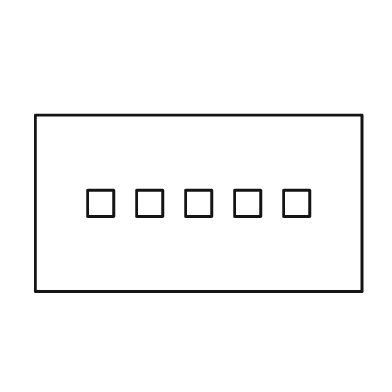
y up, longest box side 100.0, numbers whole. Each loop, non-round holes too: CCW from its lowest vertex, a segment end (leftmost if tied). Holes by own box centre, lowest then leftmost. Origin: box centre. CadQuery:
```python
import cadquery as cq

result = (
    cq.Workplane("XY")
    .moveTo(-50.0, -27.0)
    .lineTo(50.0, -27.0)
    .lineTo(50.0, 27.0)
    .lineTo(-50.0, 27.0)
    .close()
    .moveTo(-34.0, -4.0)
    .lineTo(-26.0, -4.0)
    .lineTo(-26.0, 4.0)
    .lineTo(-34.0, 4.0)
    .close()
    .moveTo(-19.0, -4.0)
    .lineTo(-11.0, -4.0)
    .lineTo(-11.0, 4.0)
    .lineTo(-19.0, 4.0)
    .close()
    .moveTo(-4.0, -4.0)
    .lineTo(4.0, -4.0)
    .lineTo(4.0, 4.0)
    .lineTo(-4.0, 4.0)
    .close()
    .moveTo(11.0, -4.0)
    .lineTo(19.0, -4.0)
    .lineTo(19.0, 4.0)
    .lineTo(11.0, 4.0)
    .close()
    .moveTo(26.0, -4.0)
    .lineTo(34.0, -4.0)
    .lineTo(34.0, 4.0)
    .lineTo(26.0, 4.0)
    .close()
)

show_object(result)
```